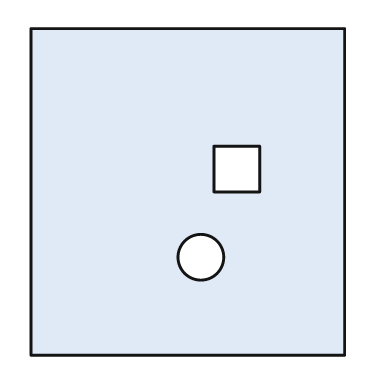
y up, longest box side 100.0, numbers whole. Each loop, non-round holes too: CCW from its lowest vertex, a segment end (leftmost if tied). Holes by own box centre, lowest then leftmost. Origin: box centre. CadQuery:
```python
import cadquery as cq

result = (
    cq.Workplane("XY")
    .moveTo(-48.0, -50.0)
    .lineTo(48.0, -50.0)
    .lineTo(48.0, 50.0)
    .lineTo(-48.0, 50.0)
    .close()
    .moveTo(4.0, -20.0)
    .circle(7.0)
    .moveTo(8.0, 0.0)
    .lineTo(22.0, 0.0)
    .lineTo(22.0, 14.0)
    .lineTo(8.0, 14.0)
    .close()
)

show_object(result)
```